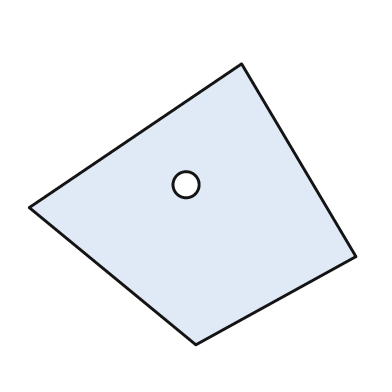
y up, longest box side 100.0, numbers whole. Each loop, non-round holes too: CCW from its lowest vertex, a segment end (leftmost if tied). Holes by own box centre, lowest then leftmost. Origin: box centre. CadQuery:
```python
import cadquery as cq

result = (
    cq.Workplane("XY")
    .moveTo(1.0, -43.0)
    .lineTo(50.0, -16.0)
    .lineTo(15.0, 43.0)
    .lineTo(-50.0, -1.0)
    .close()
    .moveTo(-2.0, 6.0)
    .circle(4.0)
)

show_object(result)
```